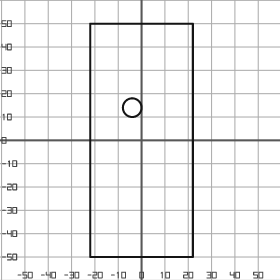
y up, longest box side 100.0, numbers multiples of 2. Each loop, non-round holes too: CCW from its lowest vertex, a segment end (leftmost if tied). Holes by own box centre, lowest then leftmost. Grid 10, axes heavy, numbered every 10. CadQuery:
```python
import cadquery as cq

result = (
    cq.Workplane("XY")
    .moveTo(-22.0, -50.0)
    .lineTo(22.0, -50.0)
    .lineTo(22.0, 50.0)
    .lineTo(-22.0, 50.0)
    .close()
    .moveTo(-4.0, 14.0)
    .circle(4.0)
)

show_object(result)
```